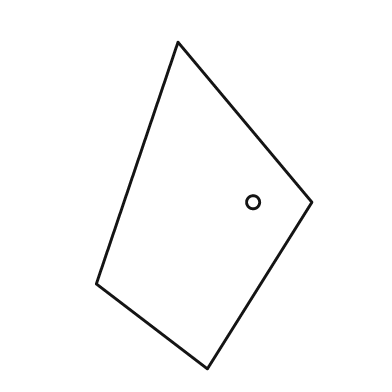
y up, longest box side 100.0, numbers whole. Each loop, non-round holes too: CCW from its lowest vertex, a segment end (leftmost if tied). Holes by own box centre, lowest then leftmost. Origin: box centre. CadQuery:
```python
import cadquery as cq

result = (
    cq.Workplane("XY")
    .moveTo(1.0, -50.0)
    .lineTo(33.0, 1.0)
    .lineTo(-8.0, 50.0)
    .lineTo(-33.0, -24.0)
    .close()
    .moveTo(15.0, 1.0)
    .circle(2.0)
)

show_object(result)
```